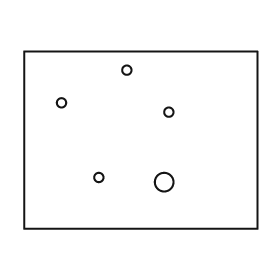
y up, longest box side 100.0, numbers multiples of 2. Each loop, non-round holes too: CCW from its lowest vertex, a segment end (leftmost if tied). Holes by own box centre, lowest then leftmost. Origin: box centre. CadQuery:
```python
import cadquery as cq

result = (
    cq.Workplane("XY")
    .moveTo(-50.0, -38.0)
    .lineTo(50.0, -38.0)
    .lineTo(50.0, 38.0)
    .lineTo(-50.0, 38.0)
    .close()
    .moveTo(10.0, -18.0)
    .circle(4.0)
    .moveTo(-18.0, -16.0)
    .circle(2.0)
    .moveTo(12.0, 12.0)
    .circle(2.0)
    .moveTo(-34.0, 16.0)
    .circle(2.0)
    .moveTo(-6.0, 30.0)
    .circle(2.0)
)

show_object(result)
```